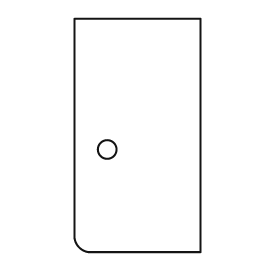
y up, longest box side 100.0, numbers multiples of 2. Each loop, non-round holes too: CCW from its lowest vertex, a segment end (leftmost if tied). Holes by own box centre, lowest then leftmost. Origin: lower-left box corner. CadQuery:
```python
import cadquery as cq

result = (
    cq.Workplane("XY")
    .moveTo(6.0, 0.0)
    .lineTo(54.0, 0.0)
    .lineTo(54.0, 100.0)
    .lineTo(0.0, 100.0)
    .lineTo(0.0, 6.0)
    .threePointArc((2.0, 2.0), (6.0, 0.0))
    .close()
    .moveTo(14.0, 44.0)
    .circle(4.0)
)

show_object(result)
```